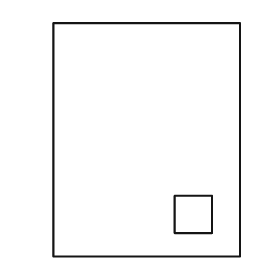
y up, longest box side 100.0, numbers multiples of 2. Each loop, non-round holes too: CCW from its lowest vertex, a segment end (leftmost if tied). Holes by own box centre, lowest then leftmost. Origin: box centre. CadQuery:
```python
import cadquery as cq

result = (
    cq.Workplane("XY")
    .moveTo(-40.0, -50.0)
    .lineTo(40.0, -50.0)
    .lineTo(40.0, 50.0)
    .lineTo(-40.0, 50.0)
    .close()
    .moveTo(12.0, -40.0)
    .lineTo(28.0, -40.0)
    .lineTo(28.0, -24.0)
    .lineTo(12.0, -24.0)
    .close()
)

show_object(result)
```